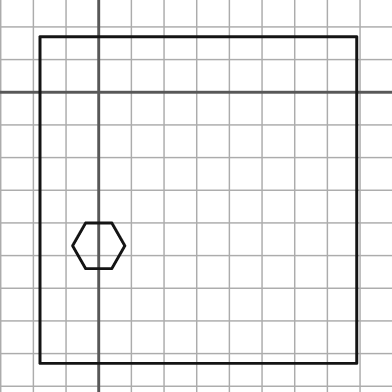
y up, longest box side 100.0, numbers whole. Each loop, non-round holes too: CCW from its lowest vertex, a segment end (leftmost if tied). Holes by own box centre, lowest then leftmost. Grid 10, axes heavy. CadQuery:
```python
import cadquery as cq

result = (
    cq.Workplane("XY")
    .moveTo(-18.0, -83.0)
    .lineTo(79.0, -83.0)
    .lineTo(79.0, 17.0)
    .lineTo(-18.0, 17.0)
    .close()
    .moveTo(-4.0, -54.0)
    .lineTo(4.0, -54.0)
    .lineTo(8.0, -47.0)
    .lineTo(4.0, -40.0)
    .lineTo(-4.0, -40.0)
    .lineTo(-8.0, -47.0)
    .close()
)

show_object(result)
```